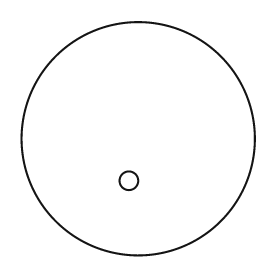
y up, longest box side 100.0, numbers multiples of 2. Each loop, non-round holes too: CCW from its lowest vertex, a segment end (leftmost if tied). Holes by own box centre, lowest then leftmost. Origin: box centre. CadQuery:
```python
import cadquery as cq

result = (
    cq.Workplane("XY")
    .moveTo(0.0, 0.0)
    .circle(50.0)
    .moveTo(-4.0, -18.0)
    .circle(4.0)
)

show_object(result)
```